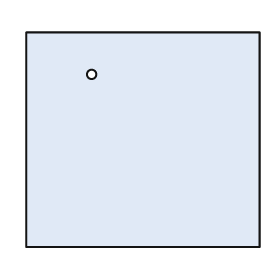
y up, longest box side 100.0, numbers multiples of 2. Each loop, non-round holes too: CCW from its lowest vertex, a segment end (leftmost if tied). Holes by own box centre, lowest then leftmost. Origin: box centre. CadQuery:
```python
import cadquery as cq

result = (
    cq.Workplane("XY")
    .moveTo(-50.0, -46.0)
    .lineTo(50.0, -46.0)
    .lineTo(50.0, 46.0)
    .lineTo(-50.0, 46.0)
    .close()
    .moveTo(-22.0, 28.0)
    .circle(2.0)
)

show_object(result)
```